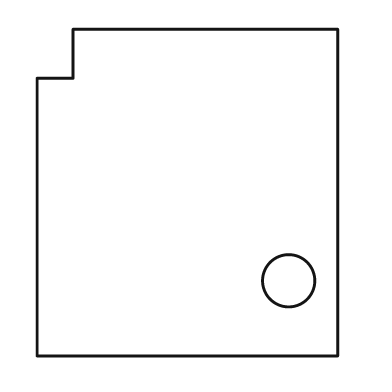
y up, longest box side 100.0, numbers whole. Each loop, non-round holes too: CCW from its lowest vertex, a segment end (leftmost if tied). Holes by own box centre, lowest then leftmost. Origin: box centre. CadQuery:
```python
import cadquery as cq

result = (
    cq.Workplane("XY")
    .moveTo(-46.0, -50.0)
    .lineTo(46.0, -50.0)
    .lineTo(46.0, 50.0)
    .lineTo(-35.0, 50.0)
    .lineTo(-35.0, 35.0)
    .lineTo(-46.0, 35.0)
    .close()
    .moveTo(31.0, -27.0)
    .circle(8.0)
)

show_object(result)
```